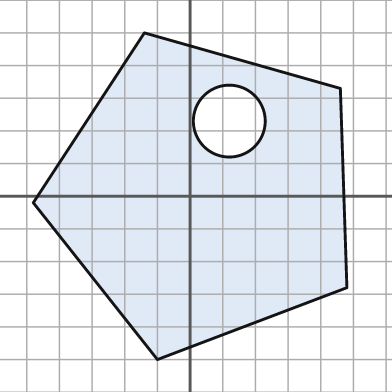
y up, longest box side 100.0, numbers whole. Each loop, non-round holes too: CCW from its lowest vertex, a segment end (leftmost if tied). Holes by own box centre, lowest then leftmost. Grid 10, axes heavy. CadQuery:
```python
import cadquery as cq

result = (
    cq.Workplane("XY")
    .moveTo(-10.0, -50.0)
    .lineTo(48.0, -28.0)
    .lineTo(46.0, 33.0)
    .lineTo(-14.0, 50.0)
    .lineTo(-48.0, -2.0)
    .close()
    .moveTo(12.0, 23.0)
    .circle(11.0)
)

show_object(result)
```